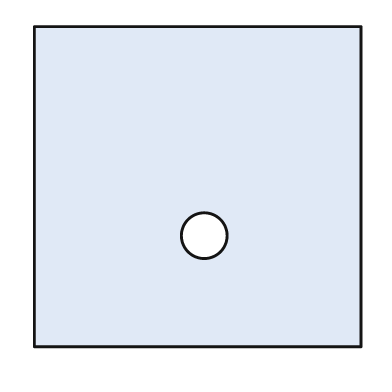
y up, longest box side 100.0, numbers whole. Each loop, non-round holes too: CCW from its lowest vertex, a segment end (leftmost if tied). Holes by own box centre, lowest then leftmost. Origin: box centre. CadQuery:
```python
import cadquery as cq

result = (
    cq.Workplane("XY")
    .moveTo(-50.0, -49.0)
    .lineTo(50.0, -49.0)
    .lineTo(50.0, 49.0)
    .lineTo(-50.0, 49.0)
    .close()
    .moveTo(2.0, -15.0)
    .circle(7.0)
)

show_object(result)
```